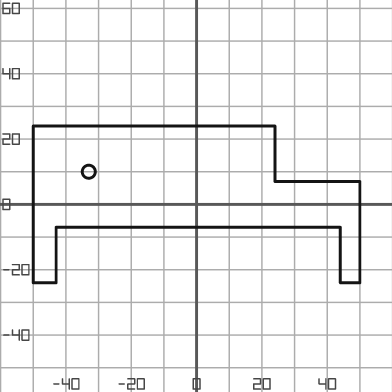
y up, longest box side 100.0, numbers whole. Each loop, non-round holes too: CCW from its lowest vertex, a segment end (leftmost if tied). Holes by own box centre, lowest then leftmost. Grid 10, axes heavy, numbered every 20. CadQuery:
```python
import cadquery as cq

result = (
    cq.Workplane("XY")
    .moveTo(-50.0, -24.0)
    .lineTo(-43.0, -24.0)
    .lineTo(-43.0, -7.0)
    .lineTo(44.0, -7.0)
    .lineTo(44.0, -24.0)
    .lineTo(50.0, -24.0)
    .lineTo(50.0, 7.0)
    .lineTo(24.0, 7.0)
    .lineTo(24.0, 24.0)
    .lineTo(-50.0, 24.0)
    .close()
    .moveTo(-33.0, 10.0)
    .circle(2.0)
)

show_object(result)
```